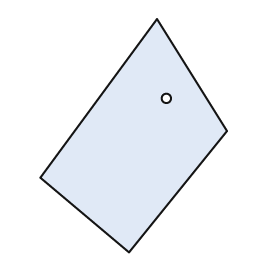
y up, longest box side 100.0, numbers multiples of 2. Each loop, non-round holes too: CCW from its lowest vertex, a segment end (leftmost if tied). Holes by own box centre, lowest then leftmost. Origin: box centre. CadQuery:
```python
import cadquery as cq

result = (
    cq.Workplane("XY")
    .moveTo(-2.0, -50.0)
    .lineTo(40.0, 2.0)
    .lineTo(10.0, 50.0)
    .lineTo(-40.0, -18.0)
    .close()
    .moveTo(14.0, 16.0)
    .circle(2.0)
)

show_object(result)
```